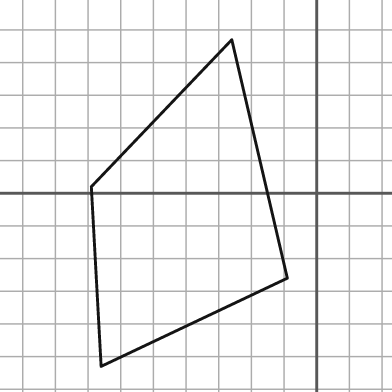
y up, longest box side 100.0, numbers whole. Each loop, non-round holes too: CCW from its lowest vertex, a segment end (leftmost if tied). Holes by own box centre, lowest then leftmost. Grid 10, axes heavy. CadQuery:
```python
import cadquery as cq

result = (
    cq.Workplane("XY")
    .moveTo(-66.0, -53.0)
    .lineTo(-9.0, -26.0)
    .lineTo(-26.0, 47.0)
    .lineTo(-69.0, 2.0)
    .close()
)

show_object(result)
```